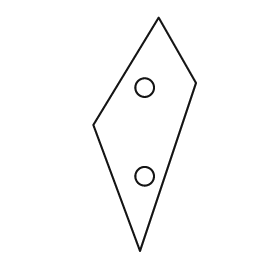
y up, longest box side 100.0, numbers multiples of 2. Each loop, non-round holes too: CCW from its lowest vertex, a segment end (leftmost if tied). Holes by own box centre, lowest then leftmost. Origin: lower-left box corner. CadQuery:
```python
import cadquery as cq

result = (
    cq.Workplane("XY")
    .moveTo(20.0, 0.0)
    .lineTo(44.0, 72.0)
    .lineTo(28.0, 100.0)
    .lineTo(0.0, 54.0)
    .close()
    .moveTo(22.0, 32.0)
    .circle(4.0)
    .moveTo(22.0, 70.0)
    .circle(4.0)
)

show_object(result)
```